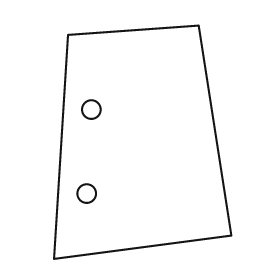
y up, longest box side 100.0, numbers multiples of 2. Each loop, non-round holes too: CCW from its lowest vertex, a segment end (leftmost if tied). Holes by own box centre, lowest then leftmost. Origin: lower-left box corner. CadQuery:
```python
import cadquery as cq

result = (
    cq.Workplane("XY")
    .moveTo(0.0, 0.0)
    .lineTo(76.0, 10.0)
    .lineTo(62.0, 100.0)
    .lineTo(6.0, 96.0)
    .close()
    .moveTo(14.0, 28.0)
    .circle(4.0)
    .moveTo(16.0, 64.0)
    .circle(4.0)
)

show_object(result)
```